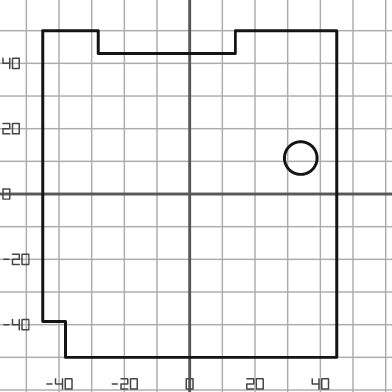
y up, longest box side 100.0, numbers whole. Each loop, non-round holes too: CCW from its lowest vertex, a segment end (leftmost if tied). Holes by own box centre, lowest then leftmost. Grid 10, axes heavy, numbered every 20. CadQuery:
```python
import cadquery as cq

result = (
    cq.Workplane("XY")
    .moveTo(-38.0, -50.0)
    .lineTo(45.0, -50.0)
    .lineTo(45.0, 50.0)
    .lineTo(14.0, 50.0)
    .lineTo(14.0, 43.0)
    .lineTo(-28.0, 43.0)
    .lineTo(-28.0, 50.0)
    .lineTo(-45.0, 50.0)
    .lineTo(-45.0, -39.0)
    .lineTo(-38.0, -39.0)
    .close()
    .moveTo(34.0, 11.0)
    .circle(5.0)
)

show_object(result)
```